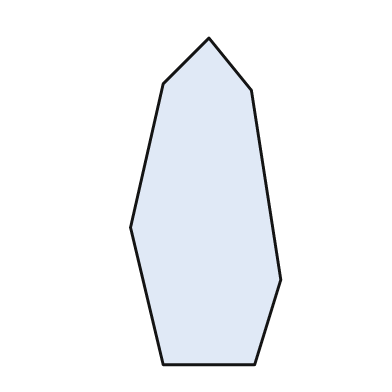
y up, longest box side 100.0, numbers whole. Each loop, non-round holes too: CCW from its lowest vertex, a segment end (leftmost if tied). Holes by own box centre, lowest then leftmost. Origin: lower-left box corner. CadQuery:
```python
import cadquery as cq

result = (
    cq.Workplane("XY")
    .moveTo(10.0, 0.0)
    .lineTo(38.0, 0.0)
    .lineTo(46.0, 26.0)
    .lineTo(37.0, 84.0)
    .lineTo(24.0, 100.0)
    .lineTo(10.0, 86.0)
    .lineTo(0.0, 42.0)
    .close()
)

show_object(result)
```